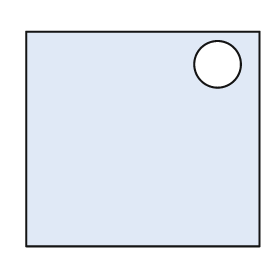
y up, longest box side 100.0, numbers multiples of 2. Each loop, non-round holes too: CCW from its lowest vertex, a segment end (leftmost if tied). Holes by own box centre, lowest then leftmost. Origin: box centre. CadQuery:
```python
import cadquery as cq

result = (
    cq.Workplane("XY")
    .moveTo(-50.0, -46.0)
    .lineTo(50.0, -46.0)
    .lineTo(50.0, 46.0)
    .lineTo(-50.0, 46.0)
    .close()
    .moveTo(32.0, 32.0)
    .circle(10.0)
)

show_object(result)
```